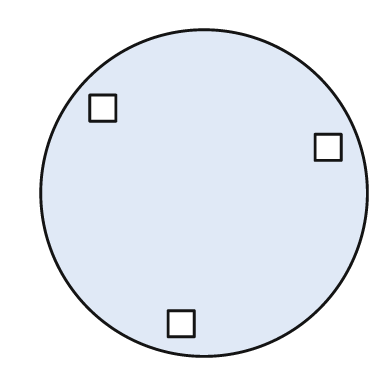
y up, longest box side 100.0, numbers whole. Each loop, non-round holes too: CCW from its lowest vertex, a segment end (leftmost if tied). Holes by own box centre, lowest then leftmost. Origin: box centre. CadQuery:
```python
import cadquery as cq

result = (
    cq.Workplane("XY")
    .moveTo(0.0, 0.0)
    .circle(50.0)
    .moveTo(-11.0, -44.0)
    .lineTo(-3.0, -44.0)
    .lineTo(-3.0, -36.0)
    .lineTo(-11.0, -36.0)
    .close()
    .moveTo(34.0, 10.0)
    .lineTo(42.0, 10.0)
    .lineTo(42.0, 18.0)
    .lineTo(34.0, 18.0)
    .close()
    .moveTo(-35.0, 22.0)
    .lineTo(-27.0, 22.0)
    .lineTo(-27.0, 30.0)
    .lineTo(-35.0, 30.0)
    .close()
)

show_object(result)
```